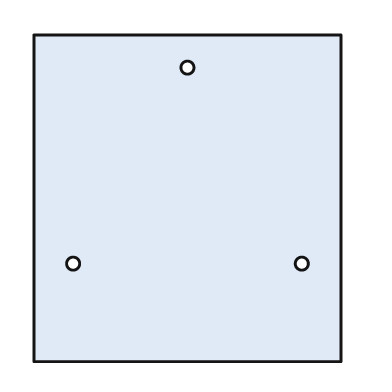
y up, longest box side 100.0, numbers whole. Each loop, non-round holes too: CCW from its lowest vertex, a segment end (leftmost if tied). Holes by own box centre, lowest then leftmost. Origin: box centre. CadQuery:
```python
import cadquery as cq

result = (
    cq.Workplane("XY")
    .moveTo(-47.0, -50.0)
    .lineTo(47.0, -50.0)
    .lineTo(47.0, 50.0)
    .lineTo(-47.0, 50.0)
    .close()
    .moveTo(-35.0, -20.0)
    .circle(2.0)
    .moveTo(35.0, -20.0)
    .circle(2.0)
    .moveTo(0.0, 40.0)
    .circle(2.0)
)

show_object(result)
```